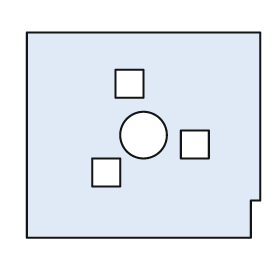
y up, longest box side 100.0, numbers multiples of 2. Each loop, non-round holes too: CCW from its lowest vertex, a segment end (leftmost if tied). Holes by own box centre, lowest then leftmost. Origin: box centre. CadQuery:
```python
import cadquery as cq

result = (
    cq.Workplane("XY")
    .moveTo(-50.0, -44.0)
    .lineTo(46.0, -44.0)
    .lineTo(46.0, -28.0)
    .lineTo(50.0, -28.0)
    .lineTo(50.0, 44.0)
    .lineTo(-50.0, 44.0)
    .close()
    .moveTo(-22.0, -22.0)
    .lineTo(-10.0, -22.0)
    .lineTo(-10.0, -10.0)
    .lineTo(-22.0, -10.0)
    .close()
    .moveTo(16.0, -10.0)
    .lineTo(28.0, -10.0)
    .lineTo(28.0, 2.0)
    .lineTo(16.0, 2.0)
    .close()
    .moveTo(0.0, 0.0)
    .circle(10.0)
    .moveTo(-12.0, 16.0)
    .lineTo(0.0, 16.0)
    .lineTo(0.0, 28.0)
    .lineTo(-12.0, 28.0)
    .close()
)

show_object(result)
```